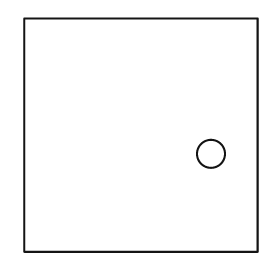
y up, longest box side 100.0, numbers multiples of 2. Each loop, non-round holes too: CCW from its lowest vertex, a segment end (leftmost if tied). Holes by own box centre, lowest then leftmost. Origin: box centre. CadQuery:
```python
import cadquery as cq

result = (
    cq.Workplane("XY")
    .moveTo(-50.0, -50.0)
    .lineTo(50.0, -50.0)
    .lineTo(50.0, 50.0)
    .lineTo(-50.0, 50.0)
    .close()
    .moveTo(30.0, -8.0)
    .circle(6.0)
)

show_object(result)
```